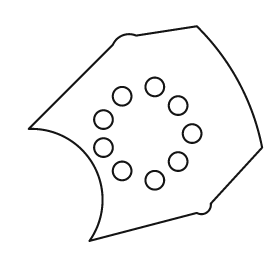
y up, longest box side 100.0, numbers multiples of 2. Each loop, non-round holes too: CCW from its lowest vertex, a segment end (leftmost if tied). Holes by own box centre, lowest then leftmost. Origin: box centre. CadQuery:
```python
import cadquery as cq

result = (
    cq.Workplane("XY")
    .moveTo(-24.0, -46.0)
    .lineTo(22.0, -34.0)
    .threePointArc((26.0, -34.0), (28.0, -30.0))
    .lineTo(50.0, -6.0)
    .threePointArc((40.0, 22.0), (22.0, 46.0))
    .lineTo(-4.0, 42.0)
    .threePointArc((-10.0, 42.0), (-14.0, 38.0))
    .lineTo(-50.0, 2.0)
    .threePointArc((-22.0, -14.0), (-24.0, -46.0))
    .close()
    .moveTo(4.0, -20.0)
    .circle(4.0)
    .moveTo(-10.0, -16.0)
    .circle(4.0)
    .moveTo(14.0, -12.0)
    .circle(4.0)
    .moveTo(-18.0, -6.0)
    .circle(4.0)
    .moveTo(20.0, 0.0)
    .circle(4.0)
    .moveTo(-18.0, 6.0)
    .circle(4.0)
    .moveTo(14.0, 12.0)
    .circle(4.0)
    .moveTo(-10.0, 16.0)
    .circle(4.0)
    .moveTo(4.0, 20.0)
    .circle(4.0)
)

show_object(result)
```